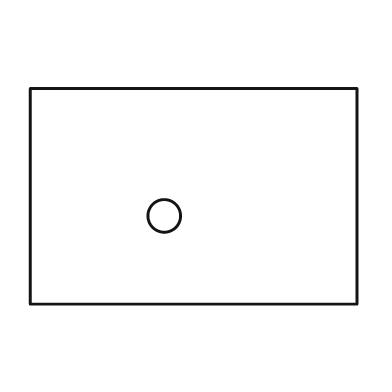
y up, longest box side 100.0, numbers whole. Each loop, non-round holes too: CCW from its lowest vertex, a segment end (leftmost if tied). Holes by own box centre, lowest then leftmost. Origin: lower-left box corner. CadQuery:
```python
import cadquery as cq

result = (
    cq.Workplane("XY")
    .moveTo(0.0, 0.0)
    .lineTo(100.0, 0.0)
    .lineTo(100.0, 66.0)
    .lineTo(0.0, 66.0)
    .close()
    .moveTo(41.0, 27.0)
    .circle(5.0)
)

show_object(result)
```